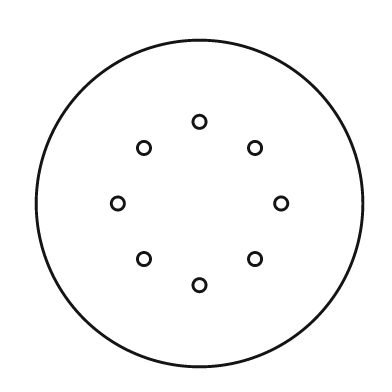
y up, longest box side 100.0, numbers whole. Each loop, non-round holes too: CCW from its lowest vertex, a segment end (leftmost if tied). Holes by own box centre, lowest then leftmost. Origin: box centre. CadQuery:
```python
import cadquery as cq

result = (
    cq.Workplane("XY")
    .moveTo(0.0, 0.0)
    .circle(50.0)
    .moveTo(0.0, -25.0)
    .circle(2.0)
    .moveTo(-17.0, -17.0)
    .circle(2.0)
    .moveTo(17.0, -17.0)
    .circle(2.0)
    .moveTo(-25.0, 0.0)
    .circle(2.0)
    .moveTo(25.0, 0.0)
    .circle(2.0)
    .moveTo(-17.0, 17.0)
    .circle(2.0)
    .moveTo(17.0, 17.0)
    .circle(2.0)
    .moveTo(0.0, 25.0)
    .circle(2.0)
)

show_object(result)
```